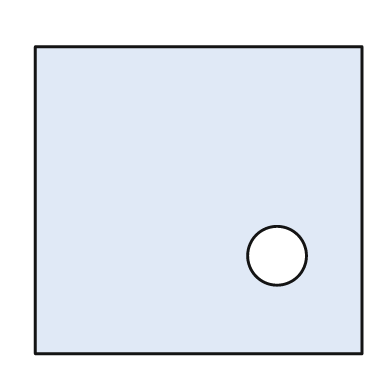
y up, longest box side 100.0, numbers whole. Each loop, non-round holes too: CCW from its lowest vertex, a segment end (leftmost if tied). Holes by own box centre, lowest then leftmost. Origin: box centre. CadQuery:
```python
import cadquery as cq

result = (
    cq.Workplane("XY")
    .moveTo(-50.0, -47.0)
    .lineTo(50.0, -47.0)
    .lineTo(50.0, 47.0)
    .lineTo(-50.0, 47.0)
    .close()
    .moveTo(24.0, -17.0)
    .circle(9.0)
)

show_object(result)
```